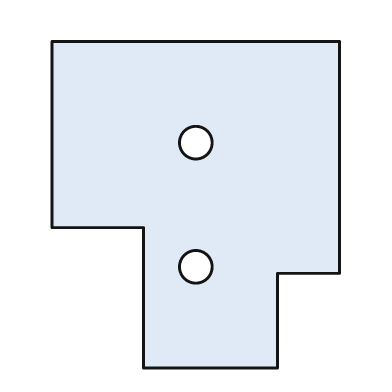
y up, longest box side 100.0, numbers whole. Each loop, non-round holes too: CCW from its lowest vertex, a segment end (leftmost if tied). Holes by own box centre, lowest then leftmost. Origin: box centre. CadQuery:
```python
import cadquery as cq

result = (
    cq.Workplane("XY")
    .moveTo(-16.0, -50.0)
    .lineTo(25.0, -50.0)
    .lineTo(25.0, -21.0)
    .lineTo(44.0, -21.0)
    .lineTo(44.0, 50.0)
    .lineTo(-44.0, 50.0)
    .lineTo(-44.0, -7.0)
    .lineTo(-16.0, -7.0)
    .close()
    .moveTo(0.0, -19.0)
    .circle(5.0)
    .moveTo(0.0, 19.0)
    .circle(5.0)
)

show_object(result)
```